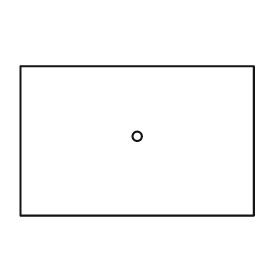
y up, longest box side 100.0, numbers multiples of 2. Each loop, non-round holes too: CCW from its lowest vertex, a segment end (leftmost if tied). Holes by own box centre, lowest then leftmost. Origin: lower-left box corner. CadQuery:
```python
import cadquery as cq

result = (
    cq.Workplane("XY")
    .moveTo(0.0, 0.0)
    .lineTo(100.0, 0.0)
    .lineTo(100.0, 64.0)
    .lineTo(0.0, 64.0)
    .close()
    .moveTo(50.0, 34.0)
    .circle(2.0)
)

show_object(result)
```